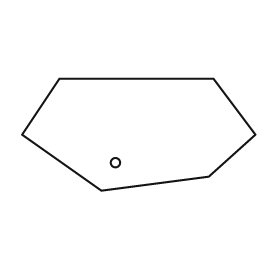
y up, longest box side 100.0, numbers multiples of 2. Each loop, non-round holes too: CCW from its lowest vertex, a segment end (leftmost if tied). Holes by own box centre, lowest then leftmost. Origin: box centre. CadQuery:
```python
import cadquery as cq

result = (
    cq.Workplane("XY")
    .moveTo(-16.0, -24.0)
    .lineTo(30.0, -18.0)
    .lineTo(50.0, 0.0)
    .lineTo(32.0, 24.0)
    .lineTo(-34.0, 24.0)
    .lineTo(-50.0, 0.0)
    .close()
    .moveTo(-10.0, -12.0)
    .circle(2.0)
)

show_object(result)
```